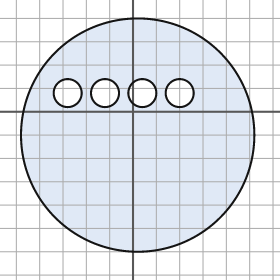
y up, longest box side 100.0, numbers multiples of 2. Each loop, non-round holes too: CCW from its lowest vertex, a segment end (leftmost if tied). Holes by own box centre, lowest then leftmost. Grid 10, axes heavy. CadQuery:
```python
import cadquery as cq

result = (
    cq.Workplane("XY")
    .moveTo(2.0, -10.0)
    .circle(50.0)
    .moveTo(-28.0, 8.0)
    .circle(6.0)
    .moveTo(-12.0, 8.0)
    .circle(6.0)
    .moveTo(4.0, 8.0)
    .circle(6.0)
    .moveTo(20.0, 8.0)
    .circle(6.0)
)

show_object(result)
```